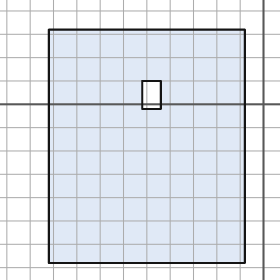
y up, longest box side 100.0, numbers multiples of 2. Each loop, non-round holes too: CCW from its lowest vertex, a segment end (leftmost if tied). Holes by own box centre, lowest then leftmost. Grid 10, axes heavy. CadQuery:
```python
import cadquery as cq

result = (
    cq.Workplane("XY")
    .moveTo(-92.0, -68.0)
    .lineTo(-8.0, -68.0)
    .lineTo(-8.0, 32.0)
    .lineTo(-92.0, 32.0)
    .close()
    .moveTo(-52.0, -2.0)
    .lineTo(-44.0, -2.0)
    .lineTo(-44.0, 10.0)
    .lineTo(-52.0, 10.0)
    .close()
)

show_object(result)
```